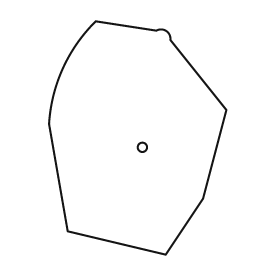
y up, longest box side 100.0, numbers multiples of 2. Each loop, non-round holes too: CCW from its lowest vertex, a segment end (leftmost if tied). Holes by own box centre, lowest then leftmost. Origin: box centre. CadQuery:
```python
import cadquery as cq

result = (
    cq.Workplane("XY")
    .moveTo(12.0, -50.0)
    .lineTo(28.0, -26.0)
    .lineTo(38.0, 12.0)
    .lineTo(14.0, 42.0)
    .threePointArc((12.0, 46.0), (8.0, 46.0))
    .lineTo(-18.0, 50.0)
    .threePointArc((-32.0, 30.0), (-38.0, 6.0))
    .lineTo(-30.0, -40.0)
    .close()
    .moveTo(2.0, -4.0)
    .circle(2.0)
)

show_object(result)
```